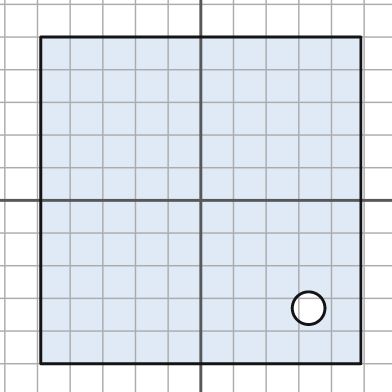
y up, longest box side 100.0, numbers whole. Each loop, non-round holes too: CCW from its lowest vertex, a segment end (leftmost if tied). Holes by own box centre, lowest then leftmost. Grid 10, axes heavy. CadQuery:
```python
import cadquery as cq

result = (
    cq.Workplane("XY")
    .moveTo(-49.0, -50.0)
    .lineTo(49.0, -50.0)
    .lineTo(49.0, 50.0)
    .lineTo(-49.0, 50.0)
    .close()
    .moveTo(33.0, -33.0)
    .circle(5.0)
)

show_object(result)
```